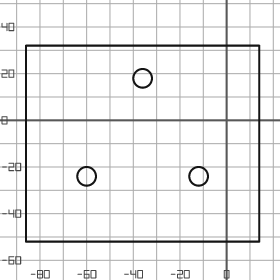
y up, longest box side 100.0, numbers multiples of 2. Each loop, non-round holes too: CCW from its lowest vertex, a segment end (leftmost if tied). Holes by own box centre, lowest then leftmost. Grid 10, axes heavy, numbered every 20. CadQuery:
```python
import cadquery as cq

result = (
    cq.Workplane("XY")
    .moveTo(-86.0, -52.0)
    .lineTo(14.0, -52.0)
    .lineTo(14.0, 32.0)
    .lineTo(-86.0, 32.0)
    .close()
    .moveTo(-60.0, -24.0)
    .circle(4.0)
    .moveTo(-12.0, -24.0)
    .circle(4.0)
    .moveTo(-36.0, 18.0)
    .circle(4.0)
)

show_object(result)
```